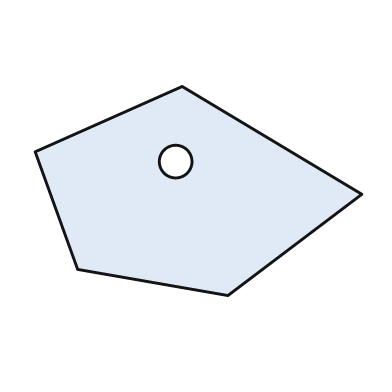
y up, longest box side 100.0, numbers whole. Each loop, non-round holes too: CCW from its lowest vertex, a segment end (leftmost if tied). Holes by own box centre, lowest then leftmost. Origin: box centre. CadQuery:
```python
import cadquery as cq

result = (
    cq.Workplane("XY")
    .moveTo(9.0, -32.0)
    .lineTo(50.0, -1.0)
    .lineTo(-5.0, 32.0)
    .lineTo(-50.0, 12.0)
    .lineTo(-37.0, -24.0)
    .close()
    .moveTo(-7.0, 9.0)
    .circle(5.0)
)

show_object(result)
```